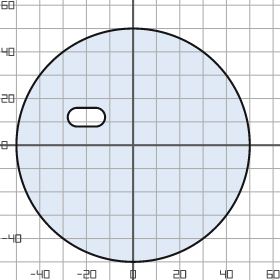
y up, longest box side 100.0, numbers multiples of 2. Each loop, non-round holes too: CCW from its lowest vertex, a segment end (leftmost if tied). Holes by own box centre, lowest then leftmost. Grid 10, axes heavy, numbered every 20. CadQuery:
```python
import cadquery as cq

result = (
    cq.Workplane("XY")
    .moveTo(0.0, 0.0)
    .circle(50.0)
    .moveTo(-24.0, 8.0)
    .lineTo(-16.0, 8.0)
    .threePointArc((-12.0, 12.0), (-16.0, 16.0))
    .lineTo(-24.0, 16.0)
    .threePointArc((-28.0, 12.0), (-24.0, 8.0))
    .close()
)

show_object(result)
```